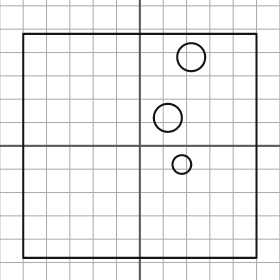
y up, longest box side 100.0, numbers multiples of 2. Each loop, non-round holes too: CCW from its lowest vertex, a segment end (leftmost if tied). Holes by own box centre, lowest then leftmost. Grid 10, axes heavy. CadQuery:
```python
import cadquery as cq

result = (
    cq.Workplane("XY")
    .moveTo(-50.0, -48.0)
    .lineTo(50.0, -48.0)
    .lineTo(50.0, 48.0)
    .lineTo(-50.0, 48.0)
    .close()
    .moveTo(18.0, -8.0)
    .circle(4.0)
    .moveTo(12.0, 12.0)
    .circle(6.0)
    .moveTo(22.0, 38.0)
    .circle(6.0)
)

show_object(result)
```